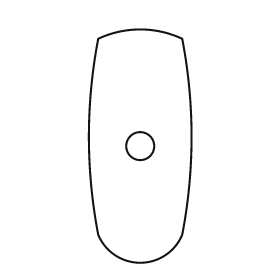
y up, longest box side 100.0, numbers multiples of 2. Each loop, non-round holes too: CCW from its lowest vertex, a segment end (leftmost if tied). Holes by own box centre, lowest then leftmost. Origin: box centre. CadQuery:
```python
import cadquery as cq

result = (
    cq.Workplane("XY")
    .moveTo(-18.0, -38.0)
    .threePointArc((0.0, -50.0), (18.0, -38.0))
    .threePointArc((22.0, 4.0), (18.0, 46.0))
    .threePointArc((0.0, 50.0), (-18.0, 46.0))
    .threePointArc((-22.0, 4.0), (-18.0, -38.0))
    .close()
    .moveTo(0.0, 0.0)
    .circle(6.0)
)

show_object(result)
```